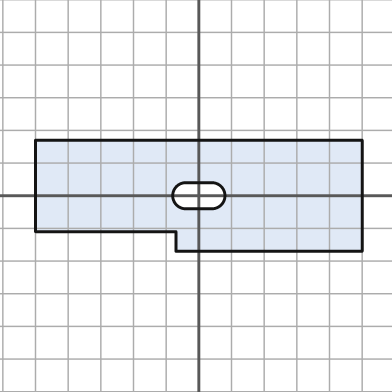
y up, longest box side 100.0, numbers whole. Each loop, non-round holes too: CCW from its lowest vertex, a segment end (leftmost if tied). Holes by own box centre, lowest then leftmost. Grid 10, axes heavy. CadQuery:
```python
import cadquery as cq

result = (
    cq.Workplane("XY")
    .moveTo(-7.0, -17.0)
    .lineTo(50.0, -17.0)
    .lineTo(50.0, 17.0)
    .lineTo(-50.0, 17.0)
    .lineTo(-50.0, -11.0)
    .lineTo(-7.0, -11.0)
    .close()
    .moveTo(-4.0, -4.0)
    .lineTo(4.0, -4.0)
    .threePointArc((8.0, 0.0), (4.0, 4.0))
    .lineTo(-4.0, 4.0)
    .threePointArc((-8.0, 0.0), (-4.0, -4.0))
    .close()
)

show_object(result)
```